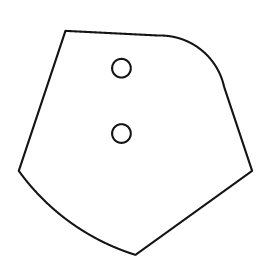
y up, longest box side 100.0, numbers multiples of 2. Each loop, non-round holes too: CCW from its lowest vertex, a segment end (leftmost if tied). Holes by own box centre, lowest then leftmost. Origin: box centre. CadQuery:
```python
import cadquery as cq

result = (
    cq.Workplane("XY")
    .moveTo(0.0, -48.0)
    .lineTo(50.0, -12.0)
    .lineTo(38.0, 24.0)
    .threePointArc((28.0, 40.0), (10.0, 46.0))
    .lineTo(-30.0, 48.0)
    .lineTo(-50.0, -12.0)
    .threePointArc((-28.0, -34.0), (0.0, -48.0))
    .close()
    .moveTo(-6.0, 4.0)
    .circle(4.0)
    .moveTo(-6.0, 32.0)
    .circle(4.0)
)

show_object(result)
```